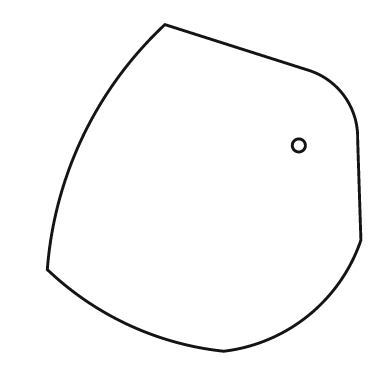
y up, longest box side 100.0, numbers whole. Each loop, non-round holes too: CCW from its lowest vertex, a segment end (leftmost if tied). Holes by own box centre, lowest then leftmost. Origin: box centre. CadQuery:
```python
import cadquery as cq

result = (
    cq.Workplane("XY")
    .moveTo(6.0, -50.0)
    .threePointArc((32.0, -39.0), (48.0, -16.0))
    .lineTo(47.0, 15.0)
    .threePointArc((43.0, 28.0), (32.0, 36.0))
    .lineTo(-12.0, 50.0)
    .threePointArc((-37.0, 16.0), (-48.0, -25.0))
    .threePointArc((-23.0, -42.0), (6.0, -50.0))
    .close()
    .moveTo(29.0, 13.0)
    .circle(2.0)
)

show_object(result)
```